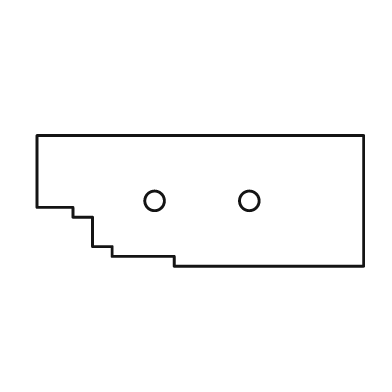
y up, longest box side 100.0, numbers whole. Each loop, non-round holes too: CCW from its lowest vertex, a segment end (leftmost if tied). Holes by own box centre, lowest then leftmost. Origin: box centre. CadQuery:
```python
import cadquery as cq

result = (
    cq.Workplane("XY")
    .moveTo(-8.0, -20.0)
    .lineTo(50.0, -20.0)
    .lineTo(50.0, 20.0)
    .lineTo(-50.0, 20.0)
    .lineTo(-50.0, -2.0)
    .lineTo(-39.0, -2.0)
    .lineTo(-39.0, -5.0)
    .lineTo(-33.0, -5.0)
    .lineTo(-33.0, -14.0)
    .lineTo(-27.0, -14.0)
    .lineTo(-27.0, -17.0)
    .lineTo(-8.0, -17.0)
    .close()
    .moveTo(-14.0, 0.0)
    .circle(3.0)
    .moveTo(15.0, 0.0)
    .circle(3.0)
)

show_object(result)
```